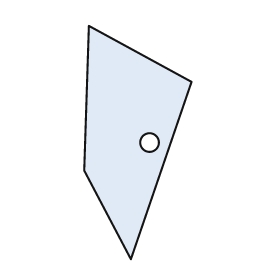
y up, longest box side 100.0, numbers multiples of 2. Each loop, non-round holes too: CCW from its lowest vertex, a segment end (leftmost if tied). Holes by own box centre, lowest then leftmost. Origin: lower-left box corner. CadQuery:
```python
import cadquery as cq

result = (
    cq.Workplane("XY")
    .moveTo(20.0, 0.0)
    .lineTo(46.0, 76.0)
    .lineTo(2.0, 100.0)
    .lineTo(0.0, 38.0)
    .close()
    .moveTo(28.0, 50.0)
    .circle(4.0)
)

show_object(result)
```